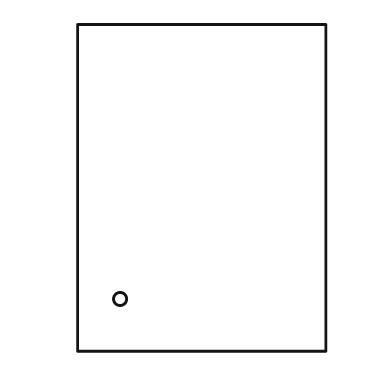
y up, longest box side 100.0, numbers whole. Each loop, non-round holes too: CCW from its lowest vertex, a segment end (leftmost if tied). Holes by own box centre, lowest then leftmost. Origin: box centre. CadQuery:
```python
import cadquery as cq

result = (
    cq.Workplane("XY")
    .moveTo(-38.0, -50.0)
    .lineTo(38.0, -50.0)
    .lineTo(38.0, 50.0)
    .lineTo(-38.0, 50.0)
    .close()
    .moveTo(-25.0, -34.0)
    .circle(2.0)
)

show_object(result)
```